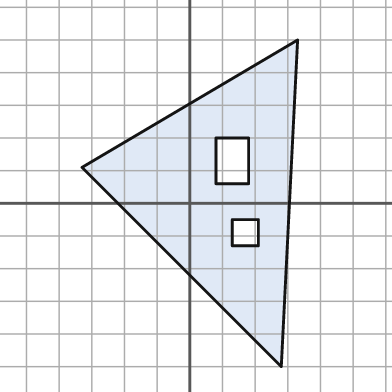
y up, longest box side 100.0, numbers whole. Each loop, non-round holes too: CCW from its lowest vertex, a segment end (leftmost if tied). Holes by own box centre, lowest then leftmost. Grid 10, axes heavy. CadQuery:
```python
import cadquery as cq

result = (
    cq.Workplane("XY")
    .moveTo(28.0, -50.0)
    .lineTo(33.0, 50.0)
    .lineTo(-33.0, 11.0)
    .close()
    .moveTo(13.0, -13.0)
    .lineTo(21.0, -13.0)
    .lineTo(21.0, -5.0)
    .lineTo(13.0, -5.0)
    .close()
    .moveTo(8.0, 6.0)
    .lineTo(18.0, 6.0)
    .lineTo(18.0, 20.0)
    .lineTo(8.0, 20.0)
    .close()
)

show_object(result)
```